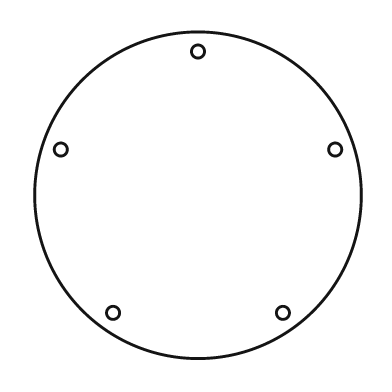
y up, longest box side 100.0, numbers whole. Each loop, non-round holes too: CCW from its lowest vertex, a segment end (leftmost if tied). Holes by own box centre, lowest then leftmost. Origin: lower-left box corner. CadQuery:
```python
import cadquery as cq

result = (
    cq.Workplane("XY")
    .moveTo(50.0, 50.0)
    .circle(50.0)
    .moveTo(24.0, 14.0)
    .circle(2.0)
    .moveTo(76.0, 14.0)
    .circle(2.0)
    .moveTo(8.0, 64.0)
    .circle(2.0)
    .moveTo(92.0, 64.0)
    .circle(2.0)
    .moveTo(50.0, 94.0)
    .circle(2.0)
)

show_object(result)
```